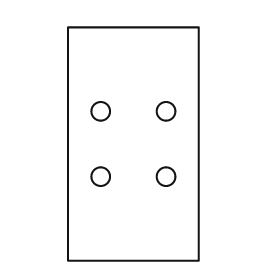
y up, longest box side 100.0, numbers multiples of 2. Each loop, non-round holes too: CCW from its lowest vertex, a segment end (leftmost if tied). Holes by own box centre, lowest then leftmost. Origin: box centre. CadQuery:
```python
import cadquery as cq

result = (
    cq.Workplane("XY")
    .moveTo(-28.0, -50.0)
    .lineTo(28.0, -50.0)
    .lineTo(28.0, 50.0)
    .lineTo(-28.0, 50.0)
    .close()
    .moveTo(-14.0, -14.0)
    .circle(4.0)
    .moveTo(14.0, -14.0)
    .circle(4.0)
    .moveTo(-14.0, 14.0)
    .circle(4.0)
    .moveTo(14.0, 14.0)
    .circle(4.0)
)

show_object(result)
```